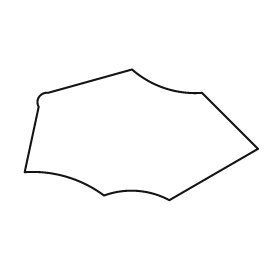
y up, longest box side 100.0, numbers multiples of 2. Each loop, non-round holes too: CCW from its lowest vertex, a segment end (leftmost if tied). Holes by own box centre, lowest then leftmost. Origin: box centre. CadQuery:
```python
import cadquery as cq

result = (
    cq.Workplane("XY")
    .moveTo(12.0, -28.0)
    .lineTo(50.0, -6.0)
    .lineTo(26.0, 18.0)
    .threePointArc((10.0, 20.0), (-4.0, 28.0))
    .lineTo(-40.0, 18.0)
    .threePointArc((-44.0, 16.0), (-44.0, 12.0))
    .lineTo(-50.0, -16.0)
    .threePointArc((-32.0, -18.0), (-16.0, -26.0))
    .threePointArc((-2.0, -24.0), (12.0, -28.0))
    .close()
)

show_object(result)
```